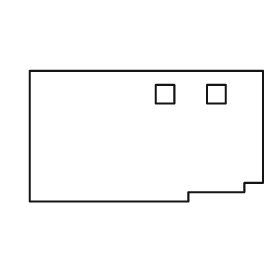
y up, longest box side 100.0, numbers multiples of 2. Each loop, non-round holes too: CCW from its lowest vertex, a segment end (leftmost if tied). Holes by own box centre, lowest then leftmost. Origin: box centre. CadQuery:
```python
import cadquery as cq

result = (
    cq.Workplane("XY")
    .moveTo(-50.0, -28.0)
    .lineTo(18.0, -28.0)
    .lineTo(18.0, -24.0)
    .lineTo(42.0, -24.0)
    .lineTo(42.0, -20.0)
    .lineTo(50.0, -20.0)
    .lineTo(50.0, 28.0)
    .lineTo(-50.0, 28.0)
    .close()
    .moveTo(4.0, 14.0)
    .lineTo(12.0, 14.0)
    .lineTo(12.0, 22.0)
    .lineTo(4.0, 22.0)
    .close()
    .moveTo(26.0, 14.0)
    .lineTo(34.0, 14.0)
    .lineTo(34.0, 22.0)
    .lineTo(26.0, 22.0)
    .close()
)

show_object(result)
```